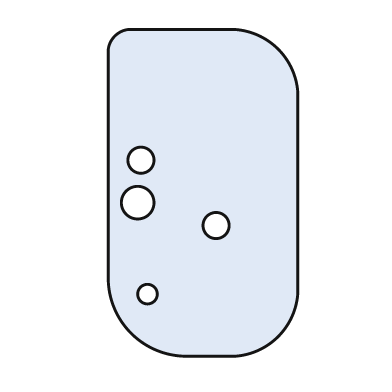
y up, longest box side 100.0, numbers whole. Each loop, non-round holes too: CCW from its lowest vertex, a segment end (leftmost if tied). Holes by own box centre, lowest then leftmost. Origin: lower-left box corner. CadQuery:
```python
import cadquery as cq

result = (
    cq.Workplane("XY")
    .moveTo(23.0, 0.0)
    .lineTo(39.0, 0.0)
    .threePointArc((52.0, 6.0), (58.0, 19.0))
    .lineTo(58.0, 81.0)
    .threePointArc((52.0, 94.0), (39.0, 100.0))
    .lineTo(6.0, 100.0)
    .threePointArc((2.0, 98.0), (0.0, 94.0))
    .lineTo(0.0, 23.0)
    .threePointArc((7.0, 7.0), (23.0, 0.0))
    .close()
    .moveTo(12.0, 19.0)
    .circle(3.0)
    .moveTo(33.0, 40.0)
    .circle(4.0)
    .moveTo(9.0, 47.0)
    .circle(5.0)
    .moveTo(10.0, 60.0)
    .circle(4.0)
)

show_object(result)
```